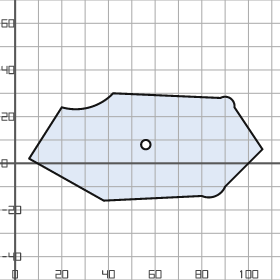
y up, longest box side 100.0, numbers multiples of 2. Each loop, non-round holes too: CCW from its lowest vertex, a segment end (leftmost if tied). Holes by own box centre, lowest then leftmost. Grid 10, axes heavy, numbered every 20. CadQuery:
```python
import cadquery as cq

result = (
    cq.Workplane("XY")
    .moveTo(38.0, -16.0)
    .lineTo(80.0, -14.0)
    .threePointArc((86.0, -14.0), (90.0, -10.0))
    .lineTo(106.0, 6.0)
    .lineTo(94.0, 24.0)
    .threePointArc((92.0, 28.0), (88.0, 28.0))
    .lineTo(42.0, 30.0)
    .threePointArc((32.0, 24.0), (20.0, 24.0))
    .lineTo(6.0, 2.0)
    .close()
    .moveTo(56.0, 8.0)
    .circle(2.0)
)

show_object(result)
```